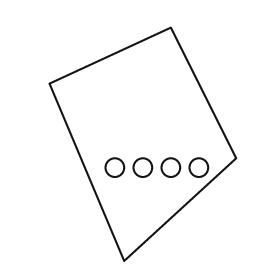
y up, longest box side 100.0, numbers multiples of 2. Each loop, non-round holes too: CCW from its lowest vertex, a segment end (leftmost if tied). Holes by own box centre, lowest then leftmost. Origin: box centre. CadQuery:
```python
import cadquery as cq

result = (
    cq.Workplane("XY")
    .moveTo(-8.0, -50.0)
    .lineTo(40.0, -6.0)
    .lineTo(12.0, 50.0)
    .lineTo(-40.0, 26.0)
    .close()
    .moveTo(-12.0, -10.0)
    .circle(4.0)
    .moveTo(0.0, -10.0)
    .circle(4.0)
    .moveTo(12.0, -10.0)
    .circle(4.0)
    .moveTo(24.0, -10.0)
    .circle(4.0)
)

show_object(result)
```